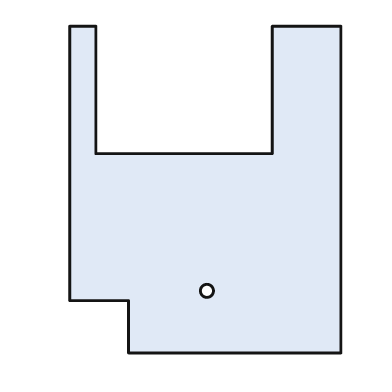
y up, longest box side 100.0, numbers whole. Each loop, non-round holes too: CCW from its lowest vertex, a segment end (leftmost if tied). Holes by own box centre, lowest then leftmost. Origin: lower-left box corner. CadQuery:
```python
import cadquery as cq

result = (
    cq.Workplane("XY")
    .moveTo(18.0, 0.0)
    .lineTo(83.0, 0.0)
    .lineTo(83.0, 100.0)
    .lineTo(62.0, 100.0)
    .lineTo(62.0, 61.0)
    .lineTo(8.0, 61.0)
    .lineTo(8.0, 100.0)
    .lineTo(0.0, 100.0)
    .lineTo(0.0, 16.0)
    .lineTo(18.0, 16.0)
    .close()
    .moveTo(42.0, 19.0)
    .circle(2.0)
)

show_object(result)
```